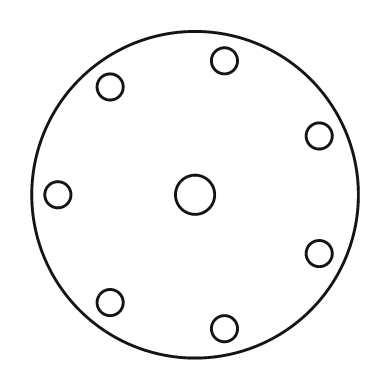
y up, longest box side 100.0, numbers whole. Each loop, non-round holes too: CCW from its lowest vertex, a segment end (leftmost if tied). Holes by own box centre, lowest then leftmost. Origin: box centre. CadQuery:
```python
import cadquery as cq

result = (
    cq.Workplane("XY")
    .moveTo(0.0, 0.0)
    .circle(50.0)
    .moveTo(9.0, -41.0)
    .circle(4.0)
    .moveTo(-26.0, -33.0)
    .circle(4.0)
    .moveTo(38.0, -18.0)
    .circle(4.0)
    .moveTo(-42.0, 0.0)
    .circle(4.0)
    .moveTo(0.0, 0.0)
    .circle(6.0)
    .moveTo(38.0, 18.0)
    .circle(4.0)
    .moveTo(-26.0, 33.0)
    .circle(4.0)
    .moveTo(9.0, 41.0)
    .circle(4.0)
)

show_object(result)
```